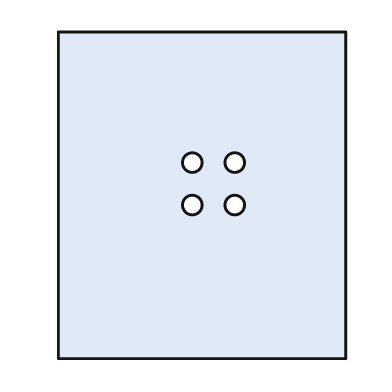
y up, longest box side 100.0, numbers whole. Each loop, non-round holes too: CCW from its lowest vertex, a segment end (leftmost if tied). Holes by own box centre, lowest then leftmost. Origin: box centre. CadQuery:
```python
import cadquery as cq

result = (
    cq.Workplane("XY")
    .moveTo(-44.0, -50.0)
    .lineTo(44.0, -50.0)
    .lineTo(44.0, 50.0)
    .lineTo(-44.0, 50.0)
    .close()
    .moveTo(-3.0, -3.0)
    .circle(3.0)
    .moveTo(10.0, -3.0)
    .circle(3.0)
    .moveTo(-3.0, 10.0)
    .circle(3.0)
    .moveTo(10.0, 10.0)
    .circle(3.0)
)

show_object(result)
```